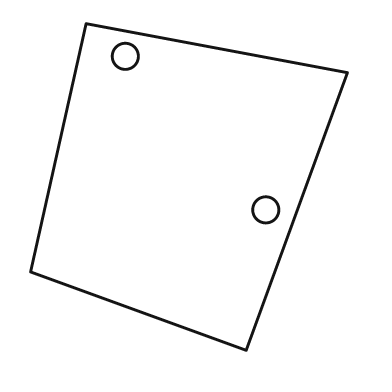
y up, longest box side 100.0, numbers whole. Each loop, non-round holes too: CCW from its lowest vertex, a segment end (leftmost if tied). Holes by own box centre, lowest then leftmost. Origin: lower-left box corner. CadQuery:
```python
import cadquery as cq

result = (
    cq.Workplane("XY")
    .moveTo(66.0, 0.0)
    .lineTo(97.0, 85.0)
    .lineTo(17.0, 100.0)
    .lineTo(0.0, 24.0)
    .close()
    .moveTo(72.0, 43.0)
    .circle(4.0)
    .moveTo(29.0, 90.0)
    .circle(4.0)
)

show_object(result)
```